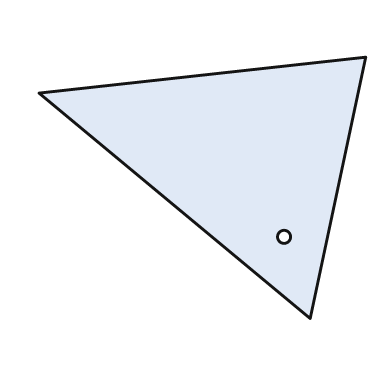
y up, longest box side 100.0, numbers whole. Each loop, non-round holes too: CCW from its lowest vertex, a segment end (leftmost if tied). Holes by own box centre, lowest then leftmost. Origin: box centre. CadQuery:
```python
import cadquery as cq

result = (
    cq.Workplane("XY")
    .moveTo(33.0, -40.0)
    .lineTo(50.0, 40.0)
    .lineTo(-50.0, 29.0)
    .close()
    .moveTo(25.0, -15.0)
    .circle(2.0)
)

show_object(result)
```